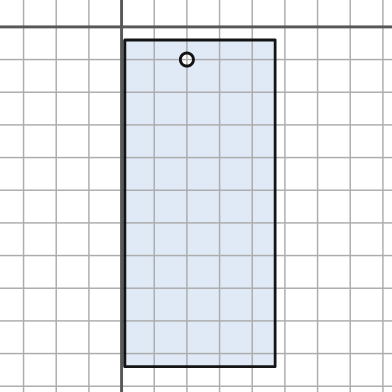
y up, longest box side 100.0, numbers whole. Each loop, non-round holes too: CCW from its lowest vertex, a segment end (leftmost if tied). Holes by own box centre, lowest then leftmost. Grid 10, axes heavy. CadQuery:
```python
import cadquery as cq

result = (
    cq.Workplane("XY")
    .moveTo(1.0, -104.0)
    .lineTo(47.0, -104.0)
    .lineTo(47.0, -4.0)
    .lineTo(1.0, -4.0)
    .close()
    .moveTo(20.0, -10.0)
    .circle(2.0)
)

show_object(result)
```